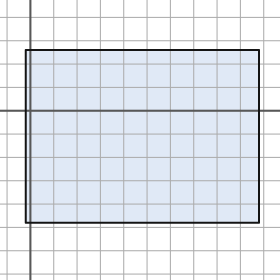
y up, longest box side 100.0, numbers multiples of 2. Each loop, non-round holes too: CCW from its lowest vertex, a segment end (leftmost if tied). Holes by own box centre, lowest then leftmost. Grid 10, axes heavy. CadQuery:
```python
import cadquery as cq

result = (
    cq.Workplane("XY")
    .moveTo(-2.0, -48.0)
    .lineTo(98.0, -48.0)
    .lineTo(98.0, 26.0)
    .lineTo(-2.0, 26.0)
    .close()
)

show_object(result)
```